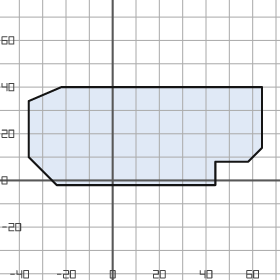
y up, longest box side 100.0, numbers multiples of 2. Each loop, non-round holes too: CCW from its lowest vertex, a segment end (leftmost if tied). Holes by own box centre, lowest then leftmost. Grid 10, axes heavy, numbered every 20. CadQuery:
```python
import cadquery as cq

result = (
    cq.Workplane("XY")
    .moveTo(-24.0, -2.0)
    .lineTo(44.0, -2.0)
    .lineTo(44.0, 8.0)
    .lineTo(58.0, 8.0)
    .lineTo(64.0, 14.0)
    .lineTo(64.0, 40.0)
    .lineTo(-22.0, 40.0)
    .lineTo(-36.0, 34.0)
    .lineTo(-36.0, 10.0)
    .close()
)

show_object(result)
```